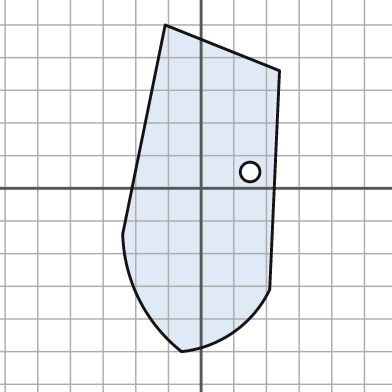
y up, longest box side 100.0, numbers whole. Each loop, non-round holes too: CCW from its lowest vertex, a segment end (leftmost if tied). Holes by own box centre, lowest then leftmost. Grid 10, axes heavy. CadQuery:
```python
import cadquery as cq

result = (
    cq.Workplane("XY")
    .moveTo(-6.0, -50.0)
    .threePointArc((10.0, -44.0), (21.0, -31.0))
    .lineTo(24.0, 36.0)
    .lineTo(-11.0, 50.0)
    .lineTo(-24.0, -14.0)
    .threePointArc((-19.0, -34.0), (-6.0, -50.0))
    .close()
    .moveTo(15.0, 5.0)
    .circle(3.0)
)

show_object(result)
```